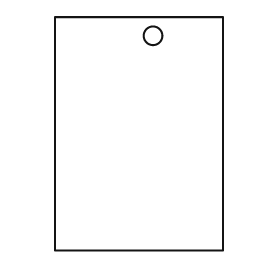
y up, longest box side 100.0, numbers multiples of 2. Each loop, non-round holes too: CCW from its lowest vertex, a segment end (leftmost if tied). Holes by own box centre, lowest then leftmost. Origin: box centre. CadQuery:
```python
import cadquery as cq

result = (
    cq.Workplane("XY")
    .moveTo(-36.0, -50.0)
    .lineTo(36.0, -50.0)
    .lineTo(36.0, 50.0)
    .lineTo(-36.0, 50.0)
    .close()
    .moveTo(6.0, 42.0)
    .circle(4.0)
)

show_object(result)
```